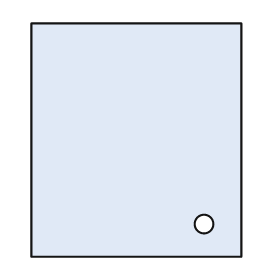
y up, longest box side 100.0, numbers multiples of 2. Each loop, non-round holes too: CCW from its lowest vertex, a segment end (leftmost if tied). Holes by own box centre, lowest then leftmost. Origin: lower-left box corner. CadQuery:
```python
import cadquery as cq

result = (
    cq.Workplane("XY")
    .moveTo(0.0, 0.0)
    .lineTo(90.0, 0.0)
    .lineTo(90.0, 100.0)
    .lineTo(0.0, 100.0)
    .close()
    .moveTo(74.0, 14.0)
    .circle(4.0)
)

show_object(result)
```